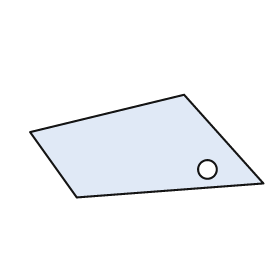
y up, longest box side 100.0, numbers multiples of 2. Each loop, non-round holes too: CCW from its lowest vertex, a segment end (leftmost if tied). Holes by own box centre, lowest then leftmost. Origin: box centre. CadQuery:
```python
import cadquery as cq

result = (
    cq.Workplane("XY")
    .moveTo(-30.0, -22.0)
    .lineTo(50.0, -16.0)
    .lineTo(16.0, 22.0)
    .lineTo(-50.0, 6.0)
    .close()
    .moveTo(26.0, -10.0)
    .circle(4.0)
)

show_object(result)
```